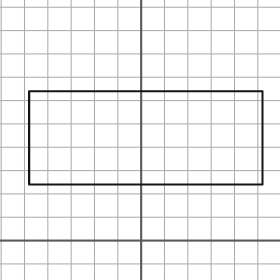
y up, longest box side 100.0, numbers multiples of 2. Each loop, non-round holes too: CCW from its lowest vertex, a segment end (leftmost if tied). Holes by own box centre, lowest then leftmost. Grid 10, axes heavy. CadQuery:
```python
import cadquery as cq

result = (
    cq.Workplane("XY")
    .moveTo(-48.0, 24.0)
    .lineTo(52.0, 24.0)
    .lineTo(52.0, 64.0)
    .lineTo(-48.0, 64.0)
    .close()
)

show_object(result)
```